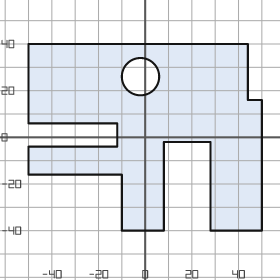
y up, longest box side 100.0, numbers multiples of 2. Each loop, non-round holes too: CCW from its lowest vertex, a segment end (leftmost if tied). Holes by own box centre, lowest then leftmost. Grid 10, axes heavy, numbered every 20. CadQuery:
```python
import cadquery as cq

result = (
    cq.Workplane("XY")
    .moveTo(-10.0, -40.0)
    .lineTo(8.0, -40.0)
    .lineTo(8.0, -2.0)
    .lineTo(28.0, -2.0)
    .lineTo(28.0, -40.0)
    .lineTo(50.0, -40.0)
    .lineTo(50.0, 16.0)
    .lineTo(44.0, 16.0)
    .lineTo(44.0, 40.0)
    .lineTo(-50.0, 40.0)
    .lineTo(-50.0, 6.0)
    .lineTo(-12.0, 6.0)
    .lineTo(-12.0, -4.0)
    .lineTo(-50.0, -4.0)
    .lineTo(-50.0, -16.0)
    .lineTo(-10.0, -16.0)
    .close()
    .moveTo(-2.0, 26.0)
    .circle(8.0)
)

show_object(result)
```